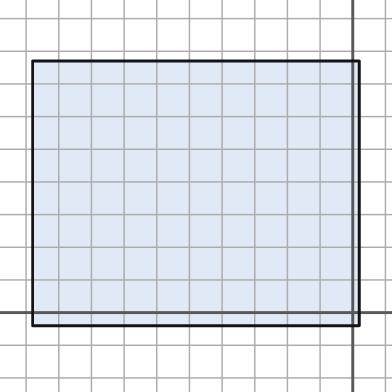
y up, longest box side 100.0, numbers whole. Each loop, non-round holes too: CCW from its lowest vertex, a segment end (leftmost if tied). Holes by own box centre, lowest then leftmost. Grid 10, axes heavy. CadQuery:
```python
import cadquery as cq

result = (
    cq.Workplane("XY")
    .moveTo(-98.0, -4.0)
    .lineTo(2.0, -4.0)
    .lineTo(2.0, 77.0)
    .lineTo(-98.0, 77.0)
    .close()
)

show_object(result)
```